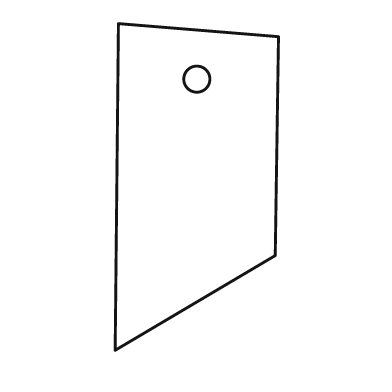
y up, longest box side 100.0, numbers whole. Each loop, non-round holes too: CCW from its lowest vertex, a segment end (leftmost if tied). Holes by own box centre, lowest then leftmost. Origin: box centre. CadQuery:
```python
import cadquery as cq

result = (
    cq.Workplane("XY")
    .moveTo(-25.0, -50.0)
    .lineTo(24.0, -21.0)
    .lineTo(25.0, 46.0)
    .lineTo(-24.0, 50.0)
    .close()
    .moveTo(0.0, 33.0)
    .circle(4.0)
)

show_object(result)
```